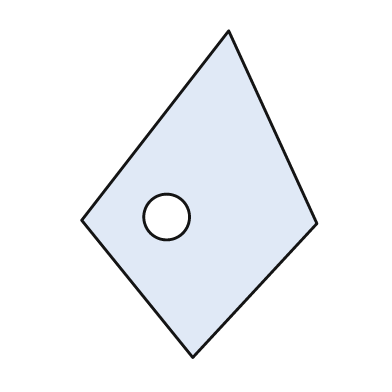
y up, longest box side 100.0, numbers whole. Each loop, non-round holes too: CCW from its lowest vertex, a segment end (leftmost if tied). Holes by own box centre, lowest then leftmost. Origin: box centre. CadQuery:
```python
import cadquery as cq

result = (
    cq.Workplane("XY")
    .moveTo(-2.0, -50.0)
    .lineTo(36.0, -9.0)
    .lineTo(9.0, 50.0)
    .lineTo(-36.0, -8.0)
    .close()
    .moveTo(-10.0, -7.0)
    .circle(7.0)
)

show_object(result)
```